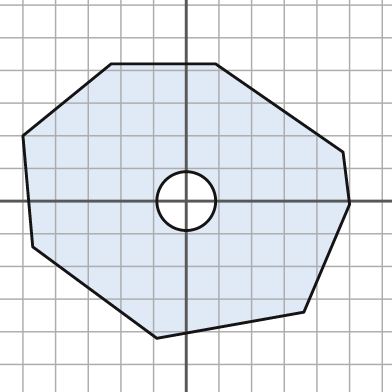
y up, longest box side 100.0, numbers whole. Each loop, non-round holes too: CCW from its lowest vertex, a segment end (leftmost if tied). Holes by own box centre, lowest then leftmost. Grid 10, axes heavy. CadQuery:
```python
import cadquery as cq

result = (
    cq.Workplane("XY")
    .moveTo(-9.0, -42.0)
    .lineTo(36.0, -34.0)
    .lineTo(50.0, -1.0)
    .lineTo(48.0, 15.0)
    .lineTo(9.0, 42.0)
    .lineTo(-23.0, 42.0)
    .lineTo(-50.0, 20.0)
    .lineTo(-47.0, -14.0)
    .close()
    .moveTo(0.0, 0.0)
    .circle(9.0)
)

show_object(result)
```